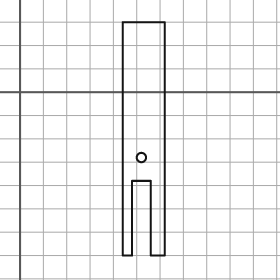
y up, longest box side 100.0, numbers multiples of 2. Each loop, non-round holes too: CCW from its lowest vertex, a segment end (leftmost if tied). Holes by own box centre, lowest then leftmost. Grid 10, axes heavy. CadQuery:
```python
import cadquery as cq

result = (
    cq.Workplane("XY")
    .moveTo(44.0, -70.0)
    .lineTo(48.0, -70.0)
    .lineTo(48.0, -38.0)
    .lineTo(56.0, -38.0)
    .lineTo(56.0, -70.0)
    .lineTo(62.0, -70.0)
    .lineTo(62.0, 30.0)
    .lineTo(44.0, 30.0)
    .close()
    .moveTo(52.0, -28.0)
    .circle(2.0)
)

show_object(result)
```